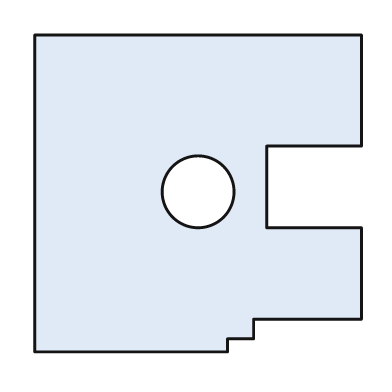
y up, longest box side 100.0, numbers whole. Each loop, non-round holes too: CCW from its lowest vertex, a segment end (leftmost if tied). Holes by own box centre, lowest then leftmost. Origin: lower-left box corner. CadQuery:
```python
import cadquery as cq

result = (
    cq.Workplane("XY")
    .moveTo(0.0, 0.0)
    .lineTo(59.0, 0.0)
    .lineTo(59.0, 4.0)
    .lineTo(67.0, 4.0)
    .lineTo(67.0, 10.0)
    .lineTo(100.0, 10.0)
    .lineTo(100.0, 38.0)
    .lineTo(71.0, 38.0)
    .lineTo(71.0, 63.0)
    .lineTo(100.0, 63.0)
    .lineTo(100.0, 97.0)
    .lineTo(0.0, 97.0)
    .close()
    .moveTo(50.0, 49.0)
    .circle(11.0)
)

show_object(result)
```